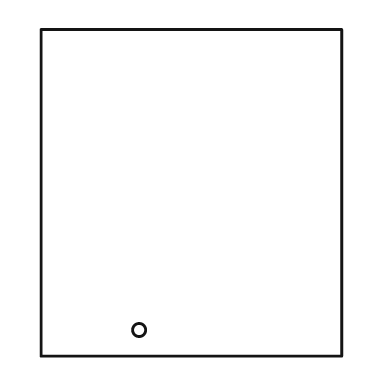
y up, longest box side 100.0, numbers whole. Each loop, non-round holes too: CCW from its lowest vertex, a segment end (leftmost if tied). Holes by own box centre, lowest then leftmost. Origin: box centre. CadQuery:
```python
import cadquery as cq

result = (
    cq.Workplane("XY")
    .moveTo(-46.0, -50.0)
    .lineTo(46.0, -50.0)
    .lineTo(46.0, 50.0)
    .lineTo(-46.0, 50.0)
    .close()
    .moveTo(-16.0, -42.0)
    .circle(2.0)
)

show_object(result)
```